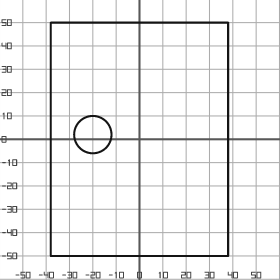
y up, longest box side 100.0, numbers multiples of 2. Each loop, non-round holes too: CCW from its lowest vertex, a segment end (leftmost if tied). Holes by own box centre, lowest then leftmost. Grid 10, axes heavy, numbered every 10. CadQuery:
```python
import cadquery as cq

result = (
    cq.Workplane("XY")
    .moveTo(-38.0, -50.0)
    .lineTo(38.0, -50.0)
    .lineTo(38.0, 50.0)
    .lineTo(-38.0, 50.0)
    .close()
    .moveTo(-20.0, 2.0)
    .circle(8.0)
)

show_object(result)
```